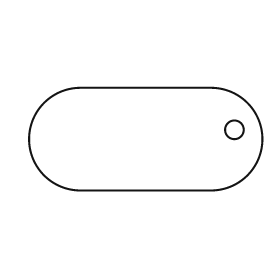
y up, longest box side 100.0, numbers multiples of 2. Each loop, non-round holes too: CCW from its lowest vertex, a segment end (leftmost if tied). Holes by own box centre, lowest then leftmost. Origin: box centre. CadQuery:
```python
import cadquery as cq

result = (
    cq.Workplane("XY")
    .moveTo(-28.0, -22.0)
    .lineTo(28.0, -22.0)
    .threePointArc((50.0, 0.0), (28.0, 22.0))
    .lineTo(-28.0, 22.0)
    .threePointArc((-50.0, 0.0), (-28.0, -22.0))
    .close()
    .moveTo(38.0, 4.0)
    .circle(4.0)
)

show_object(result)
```